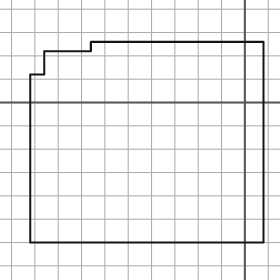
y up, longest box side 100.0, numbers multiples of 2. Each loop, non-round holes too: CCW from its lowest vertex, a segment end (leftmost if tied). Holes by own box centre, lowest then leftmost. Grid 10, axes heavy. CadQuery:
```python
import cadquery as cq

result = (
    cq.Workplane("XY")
    .moveTo(-92.0, -60.0)
    .lineTo(8.0, -60.0)
    .lineTo(8.0, 26.0)
    .lineTo(-66.0, 26.0)
    .lineTo(-66.0, 22.0)
    .lineTo(-86.0, 22.0)
    .lineTo(-86.0, 12.0)
    .lineTo(-92.0, 12.0)
    .close()
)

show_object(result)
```